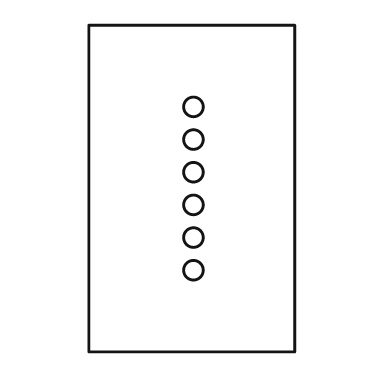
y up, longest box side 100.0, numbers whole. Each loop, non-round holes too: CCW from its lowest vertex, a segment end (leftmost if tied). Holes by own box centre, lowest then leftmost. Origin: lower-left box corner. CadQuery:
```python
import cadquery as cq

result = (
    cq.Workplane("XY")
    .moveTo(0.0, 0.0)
    .lineTo(63.0, 0.0)
    .lineTo(63.0, 100.0)
    .lineTo(0.0, 100.0)
    .close()
    .moveTo(32.0, 25.0)
    .circle(3.0)
    .moveTo(32.0, 35.0)
    .circle(3.0)
    .moveTo(32.0, 45.0)
    .circle(3.0)
    .moveTo(32.0, 55.0)
    .circle(3.0)
    .moveTo(32.0, 65.0)
    .circle(3.0)
    .moveTo(32.0, 75.0)
    .circle(3.0)
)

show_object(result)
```